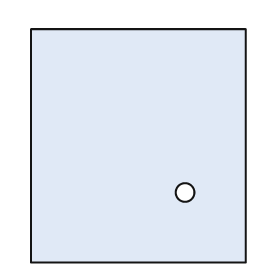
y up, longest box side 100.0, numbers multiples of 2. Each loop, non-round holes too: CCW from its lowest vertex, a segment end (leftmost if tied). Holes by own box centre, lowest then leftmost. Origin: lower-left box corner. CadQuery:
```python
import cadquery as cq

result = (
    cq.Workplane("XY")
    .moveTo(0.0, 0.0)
    .lineTo(92.0, 0.0)
    .lineTo(92.0, 100.0)
    .lineTo(0.0, 100.0)
    .close()
    .moveTo(66.0, 30.0)
    .circle(4.0)
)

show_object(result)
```